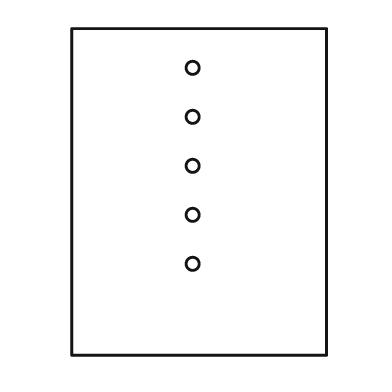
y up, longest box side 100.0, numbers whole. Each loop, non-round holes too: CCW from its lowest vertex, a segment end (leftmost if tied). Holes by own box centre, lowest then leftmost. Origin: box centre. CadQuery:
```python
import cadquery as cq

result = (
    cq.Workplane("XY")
    .moveTo(-39.0, -50.0)
    .lineTo(39.0, -50.0)
    .lineTo(39.0, 50.0)
    .lineTo(-39.0, 50.0)
    .close()
    .moveTo(-2.0, -22.0)
    .circle(2.0)
    .moveTo(-2.0, -7.0)
    .circle(2.0)
    .moveTo(-2.0, 8.0)
    .circle(2.0)
    .moveTo(-2.0, 23.0)
    .circle(2.0)
    .moveTo(-2.0, 38.0)
    .circle(2.0)
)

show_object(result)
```